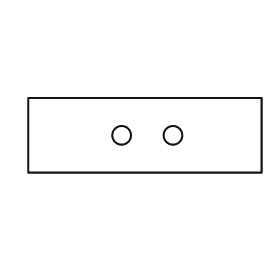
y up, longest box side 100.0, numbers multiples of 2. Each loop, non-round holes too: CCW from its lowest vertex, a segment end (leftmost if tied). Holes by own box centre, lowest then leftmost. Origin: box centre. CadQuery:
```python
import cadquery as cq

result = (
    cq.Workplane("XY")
    .moveTo(-50.0, -16.0)
    .lineTo(50.0, -16.0)
    .lineTo(50.0, 16.0)
    .lineTo(-50.0, 16.0)
    .close()
    .moveTo(-10.0, 0.0)
    .circle(4.0)
    .moveTo(12.0, 0.0)
    .circle(4.0)
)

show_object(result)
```